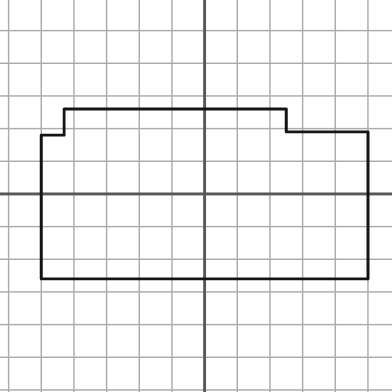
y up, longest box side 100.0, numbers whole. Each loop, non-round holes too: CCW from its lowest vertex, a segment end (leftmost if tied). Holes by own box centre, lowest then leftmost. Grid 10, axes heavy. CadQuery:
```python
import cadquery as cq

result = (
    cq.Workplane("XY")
    .moveTo(-50.0, -26.0)
    .lineTo(50.0, -26.0)
    .lineTo(50.0, 19.0)
    .lineTo(25.0, 19.0)
    .lineTo(25.0, 26.0)
    .lineTo(-43.0, 26.0)
    .lineTo(-43.0, 18.0)
    .lineTo(-50.0, 18.0)
    .close()
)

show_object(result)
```